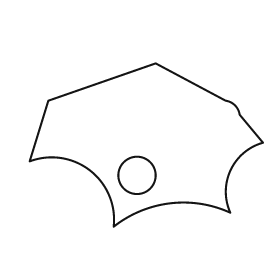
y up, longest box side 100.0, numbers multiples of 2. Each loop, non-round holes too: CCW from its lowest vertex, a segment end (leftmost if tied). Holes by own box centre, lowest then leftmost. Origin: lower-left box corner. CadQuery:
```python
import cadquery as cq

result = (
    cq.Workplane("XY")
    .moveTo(36.0, 0.0)
    .threePointArc((60.0, 10.0), (86.0, 6.0))
    .threePointArc((86.0, 24.0), (100.0, 36.0))
    .lineTo(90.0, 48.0)
    .threePointArc((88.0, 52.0), (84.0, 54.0))
    .lineTo(54.0, 70.0)
    .lineTo(8.0, 54.0)
    .lineTo(0.0, 28.0)
    .threePointArc((26.0, 24.0), (36.0, 0.0))
    .close()
    .moveTo(46.0, 22.0)
    .circle(8.0)
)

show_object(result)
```